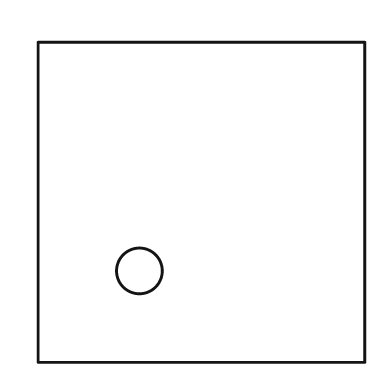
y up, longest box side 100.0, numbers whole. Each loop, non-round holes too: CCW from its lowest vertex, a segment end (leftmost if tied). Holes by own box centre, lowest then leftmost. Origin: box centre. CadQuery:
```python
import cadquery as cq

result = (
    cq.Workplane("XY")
    .moveTo(-50.0, -49.0)
    .lineTo(50.0, -49.0)
    .lineTo(50.0, 49.0)
    .lineTo(-50.0, 49.0)
    .close()
    .moveTo(-19.0, -21.0)
    .circle(7.0)
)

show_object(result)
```